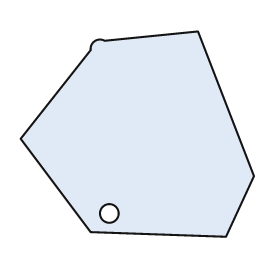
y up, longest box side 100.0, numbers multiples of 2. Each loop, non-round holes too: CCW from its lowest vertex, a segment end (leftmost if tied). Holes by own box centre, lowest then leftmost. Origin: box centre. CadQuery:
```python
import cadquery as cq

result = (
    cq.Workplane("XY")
    .moveTo(38.0, -44.0)
    .lineTo(50.0, -18.0)
    .lineTo(26.0, 44.0)
    .lineTo(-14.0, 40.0)
    .threePointArc((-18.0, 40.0), (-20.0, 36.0))
    .lineTo(-50.0, -2.0)
    .lineTo(-20.0, -42.0)
    .close()
    .moveTo(-12.0, -34.0)
    .circle(4.0)
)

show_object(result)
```